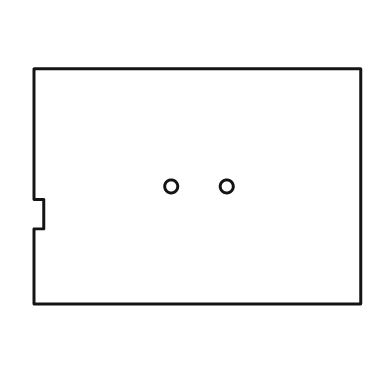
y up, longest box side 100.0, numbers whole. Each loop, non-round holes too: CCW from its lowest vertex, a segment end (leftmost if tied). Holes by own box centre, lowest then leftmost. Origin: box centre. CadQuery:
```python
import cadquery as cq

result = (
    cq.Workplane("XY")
    .moveTo(-50.0, -36.0)
    .lineTo(50.0, -36.0)
    .lineTo(50.0, 36.0)
    .lineTo(-50.0, 36.0)
    .lineTo(-50.0, -4.0)
    .lineTo(-47.0, -4.0)
    .lineTo(-47.0, -13.0)
    .lineTo(-50.0, -13.0)
    .close()
    .moveTo(-8.0, 0.0)
    .circle(2.0)
    .moveTo(9.0, 0.0)
    .circle(2.0)
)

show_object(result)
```